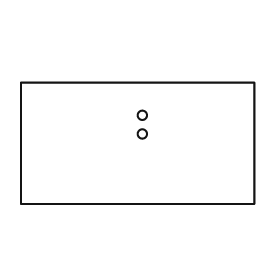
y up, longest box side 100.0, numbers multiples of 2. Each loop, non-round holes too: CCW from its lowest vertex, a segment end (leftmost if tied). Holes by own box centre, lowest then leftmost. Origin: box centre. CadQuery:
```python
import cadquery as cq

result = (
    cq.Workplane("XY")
    .moveTo(-50.0, -26.0)
    .lineTo(50.0, -26.0)
    .lineTo(50.0, 26.0)
    .lineTo(-50.0, 26.0)
    .close()
    .moveTo(2.0, 4.0)
    .circle(2.0)
    .moveTo(2.0, 12.0)
    .circle(2.0)
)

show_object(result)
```